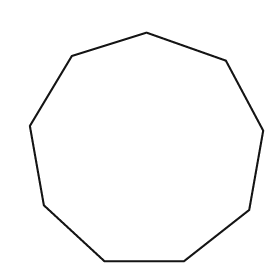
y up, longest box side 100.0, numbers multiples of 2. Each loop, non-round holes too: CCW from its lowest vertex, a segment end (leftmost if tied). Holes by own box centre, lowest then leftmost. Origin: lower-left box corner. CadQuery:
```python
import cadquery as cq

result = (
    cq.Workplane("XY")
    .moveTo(32.0, 0.0)
    .lineTo(66.0, 0.0)
    .lineTo(94.0, 22.0)
    .lineTo(100.0, 56.0)
    .lineTo(84.0, 86.0)
    .lineTo(50.0, 98.0)
    .lineTo(18.0, 88.0)
    .lineTo(0.0, 58.0)
    .lineTo(6.0, 24.0)
    .close()
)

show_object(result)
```